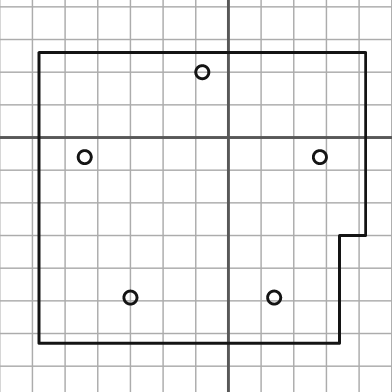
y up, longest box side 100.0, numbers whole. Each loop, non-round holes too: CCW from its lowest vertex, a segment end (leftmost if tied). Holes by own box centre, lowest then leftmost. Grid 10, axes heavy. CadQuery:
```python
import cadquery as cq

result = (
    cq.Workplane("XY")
    .moveTo(-58.0, -63.0)
    .lineTo(34.0, -63.0)
    .lineTo(34.0, -30.0)
    .lineTo(42.0, -30.0)
    .lineTo(42.0, 26.0)
    .lineTo(-58.0, 26.0)
    .close()
    .moveTo(-30.0, -49.0)
    .circle(2.0)
    .moveTo(14.0, -49.0)
    .circle(2.0)
    .moveTo(-44.0, -6.0)
    .circle(2.0)
    .moveTo(28.0, -6.0)
    .circle(2.0)
    .moveTo(-8.0, 20.0)
    .circle(2.0)
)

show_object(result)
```